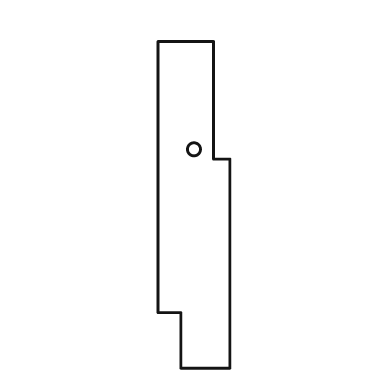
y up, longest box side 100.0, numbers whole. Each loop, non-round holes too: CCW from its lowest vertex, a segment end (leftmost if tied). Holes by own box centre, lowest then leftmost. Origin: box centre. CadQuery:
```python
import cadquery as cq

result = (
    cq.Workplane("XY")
    .moveTo(-4.0, -50.0)
    .lineTo(11.0, -50.0)
    .lineTo(11.0, 14.0)
    .lineTo(6.0, 14.0)
    .lineTo(6.0, 50.0)
    .lineTo(-11.0, 50.0)
    .lineTo(-11.0, -33.0)
    .lineTo(-4.0, -33.0)
    .close()
    .moveTo(0.0, 17.0)
    .circle(2.0)
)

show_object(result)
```